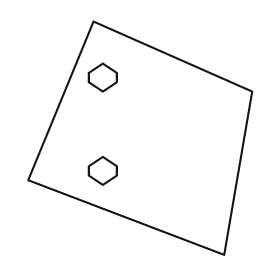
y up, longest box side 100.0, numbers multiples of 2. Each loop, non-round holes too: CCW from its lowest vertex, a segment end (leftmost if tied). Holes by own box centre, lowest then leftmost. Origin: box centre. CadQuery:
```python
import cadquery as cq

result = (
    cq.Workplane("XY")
    .moveTo(36.0, -50.0)
    .lineTo(48.0, 20.0)
    .lineTo(-20.0, 50.0)
    .lineTo(-48.0, -18.0)
    .close()
    .moveTo(-16.0, -20.0)
    .lineTo(-10.0, -16.0)
    .lineTo(-10.0, -12.0)
    .lineTo(-16.0, -8.0)
    .lineTo(-22.0, -12.0)
    .lineTo(-22.0, -16.0)
    .close()
    .moveTo(-16.0, 20.0)
    .lineTo(-10.0, 24.0)
    .lineTo(-10.0, 28.0)
    .lineTo(-16.0, 32.0)
    .lineTo(-22.0, 28.0)
    .lineTo(-22.0, 24.0)
    .close()
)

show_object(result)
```